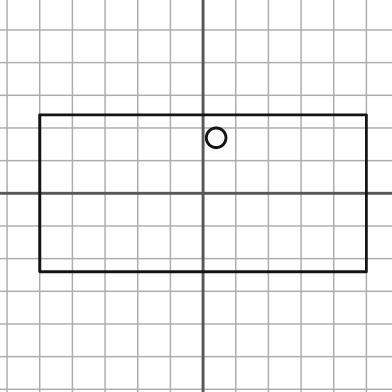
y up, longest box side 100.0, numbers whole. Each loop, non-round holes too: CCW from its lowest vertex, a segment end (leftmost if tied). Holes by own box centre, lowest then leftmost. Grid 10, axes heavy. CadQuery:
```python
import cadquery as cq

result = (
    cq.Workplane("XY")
    .moveTo(-50.0, -24.0)
    .lineTo(50.0, -24.0)
    .lineTo(50.0, 24.0)
    .lineTo(-50.0, 24.0)
    .close()
    .moveTo(4.0, 17.0)
    .circle(3.0)
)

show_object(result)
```